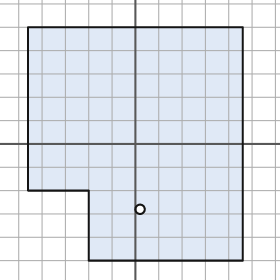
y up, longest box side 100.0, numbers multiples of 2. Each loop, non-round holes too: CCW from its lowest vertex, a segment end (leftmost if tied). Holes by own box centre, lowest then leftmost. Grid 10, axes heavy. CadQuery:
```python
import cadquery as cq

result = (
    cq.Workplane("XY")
    .moveTo(-20.0, -50.0)
    .lineTo(46.0, -50.0)
    .lineTo(46.0, 50.0)
    .lineTo(-46.0, 50.0)
    .lineTo(-46.0, -20.0)
    .lineTo(-20.0, -20.0)
    .close()
    .moveTo(2.0, -28.0)
    .circle(2.0)
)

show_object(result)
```